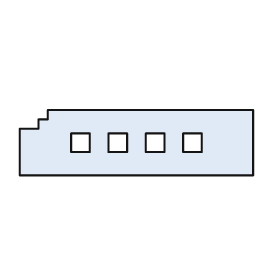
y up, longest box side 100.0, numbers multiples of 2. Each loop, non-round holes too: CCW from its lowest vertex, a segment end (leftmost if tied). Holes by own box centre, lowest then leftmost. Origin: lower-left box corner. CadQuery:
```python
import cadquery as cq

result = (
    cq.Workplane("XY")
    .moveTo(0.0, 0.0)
    .lineTo(100.0, 0.0)
    .lineTo(100.0, 28.0)
    .lineTo(12.0, 28.0)
    .lineTo(12.0, 24.0)
    .lineTo(8.0, 24.0)
    .lineTo(8.0, 20.0)
    .lineTo(0.0, 20.0)
    .close()
    .moveTo(22.0, 10.0)
    .lineTo(30.0, 10.0)
    .lineTo(30.0, 18.0)
    .lineTo(22.0, 18.0)
    .close()
    .moveTo(38.0, 10.0)
    .lineTo(46.0, 10.0)
    .lineTo(46.0, 18.0)
    .lineTo(38.0, 18.0)
    .close()
    .moveTo(54.0, 10.0)
    .lineTo(62.0, 10.0)
    .lineTo(62.0, 18.0)
    .lineTo(54.0, 18.0)
    .close()
    .moveTo(70.0, 10.0)
    .lineTo(78.0, 10.0)
    .lineTo(78.0, 18.0)
    .lineTo(70.0, 18.0)
    .close()
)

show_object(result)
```